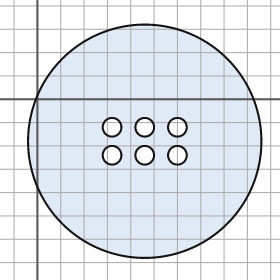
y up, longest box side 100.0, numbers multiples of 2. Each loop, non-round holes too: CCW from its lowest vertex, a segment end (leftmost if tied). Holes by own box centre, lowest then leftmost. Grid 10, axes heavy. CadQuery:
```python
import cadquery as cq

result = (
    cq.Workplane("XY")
    .moveTo(46.0, -18.0)
    .circle(50.0)
    .moveTo(32.0, -24.0)
    .circle(4.0)
    .moveTo(46.0, -24.0)
    .circle(4.0)
    .moveTo(60.0, -24.0)
    .circle(4.0)
    .moveTo(32.0, -12.0)
    .circle(4.0)
    .moveTo(46.0, -12.0)
    .circle(4.0)
    .moveTo(60.0, -12.0)
    .circle(4.0)
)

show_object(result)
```